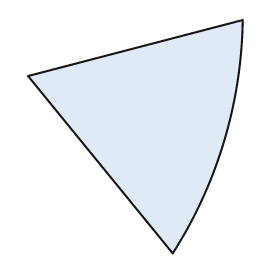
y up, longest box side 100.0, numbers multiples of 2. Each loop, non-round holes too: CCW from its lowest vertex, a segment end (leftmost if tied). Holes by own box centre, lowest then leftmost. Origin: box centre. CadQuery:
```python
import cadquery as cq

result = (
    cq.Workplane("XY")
    .moveTo(16.0, -50.0)
    .threePointArc((38.0, -2.0), (46.0, 50.0))
    .lineTo(-46.0, 26.0)
    .close()
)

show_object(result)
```